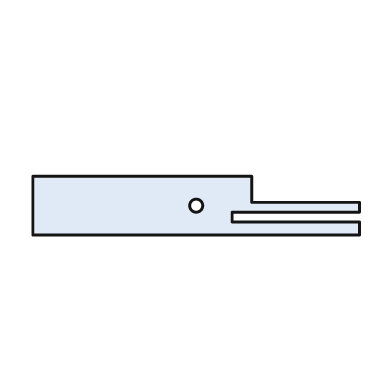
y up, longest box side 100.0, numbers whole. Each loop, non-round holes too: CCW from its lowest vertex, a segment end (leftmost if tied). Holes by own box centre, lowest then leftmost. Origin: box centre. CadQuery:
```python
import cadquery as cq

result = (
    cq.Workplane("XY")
    .moveTo(-50.0, -9.0)
    .lineTo(50.0, -9.0)
    .lineTo(50.0, -5.0)
    .lineTo(11.0, -5.0)
    .lineTo(11.0, -2.0)
    .lineTo(50.0, -2.0)
    .lineTo(50.0, 1.0)
    .lineTo(17.0, 1.0)
    .lineTo(17.0, 9.0)
    .lineTo(-50.0, 9.0)
    .close()
    .moveTo(0.0, 0.0)
    .circle(2.0)
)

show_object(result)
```